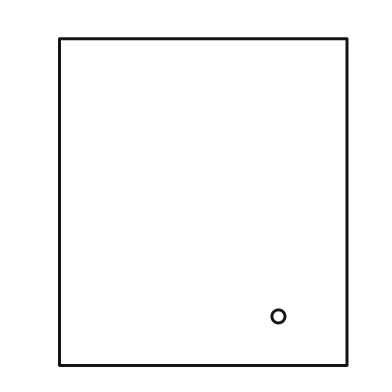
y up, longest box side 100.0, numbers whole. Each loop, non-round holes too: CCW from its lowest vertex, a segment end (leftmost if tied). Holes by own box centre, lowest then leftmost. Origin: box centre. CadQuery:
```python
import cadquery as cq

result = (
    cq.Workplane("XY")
    .moveTo(-44.0, -50.0)
    .lineTo(44.0, -50.0)
    .lineTo(44.0, 50.0)
    .lineTo(-44.0, 50.0)
    .close()
    .moveTo(23.0, -35.0)
    .circle(2.0)
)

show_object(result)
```